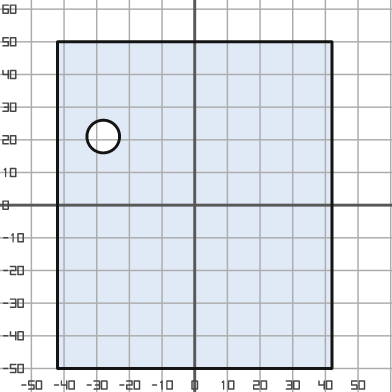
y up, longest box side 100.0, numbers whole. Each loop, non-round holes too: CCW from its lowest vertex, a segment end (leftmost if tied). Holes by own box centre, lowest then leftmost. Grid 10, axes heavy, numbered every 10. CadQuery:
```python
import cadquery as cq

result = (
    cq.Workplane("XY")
    .moveTo(-42.0, -50.0)
    .lineTo(42.0, -50.0)
    .lineTo(42.0, 50.0)
    .lineTo(-42.0, 50.0)
    .close()
    .moveTo(-28.0, 21.0)
    .circle(5.0)
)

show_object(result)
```